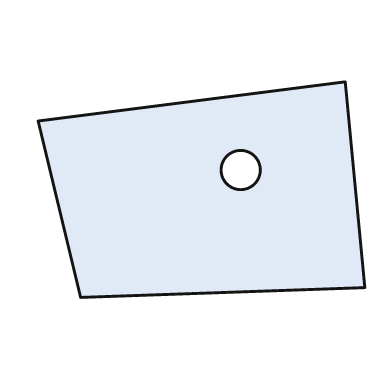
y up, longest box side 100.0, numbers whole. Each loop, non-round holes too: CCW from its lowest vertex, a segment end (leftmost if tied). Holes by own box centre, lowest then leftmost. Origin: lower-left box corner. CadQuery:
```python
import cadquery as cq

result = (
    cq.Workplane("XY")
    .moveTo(13.0, 0.0)
    .lineTo(100.0, 3.0)
    .lineTo(94.0, 66.0)
    .lineTo(0.0, 54.0)
    .close()
    .moveTo(62.0, 39.0)
    .circle(6.0)
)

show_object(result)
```